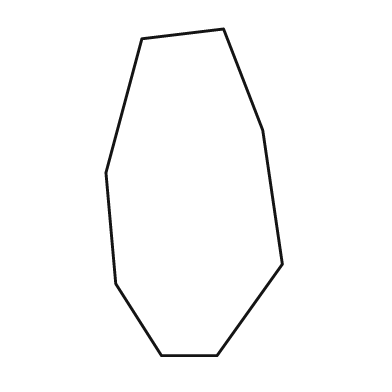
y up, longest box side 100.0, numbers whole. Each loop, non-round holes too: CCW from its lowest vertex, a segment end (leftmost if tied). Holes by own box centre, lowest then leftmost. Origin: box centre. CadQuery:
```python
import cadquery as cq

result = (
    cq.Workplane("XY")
    .moveTo(-10.0, -50.0)
    .lineTo(7.0, -50.0)
    .lineTo(27.0, -22.0)
    .lineTo(21.0, 19.0)
    .lineTo(9.0, 50.0)
    .lineTo(-16.0, 47.0)
    .lineTo(-27.0, 6.0)
    .lineTo(-24.0, -28.0)
    .close()
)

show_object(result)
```